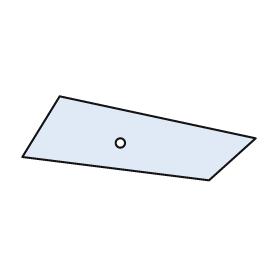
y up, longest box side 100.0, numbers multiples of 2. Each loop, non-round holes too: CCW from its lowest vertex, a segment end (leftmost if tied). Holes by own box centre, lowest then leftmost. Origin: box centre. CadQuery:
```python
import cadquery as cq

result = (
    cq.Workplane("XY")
    .moveTo(30.0, -18.0)
    .lineTo(50.0, 0.0)
    .lineTo(-34.0, 18.0)
    .lineTo(-50.0, -8.0)
    .close()
    .moveTo(-8.0, -2.0)
    .circle(2.0)
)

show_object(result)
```